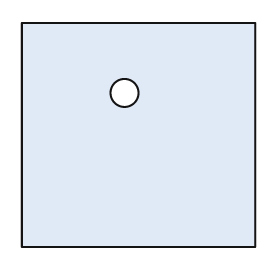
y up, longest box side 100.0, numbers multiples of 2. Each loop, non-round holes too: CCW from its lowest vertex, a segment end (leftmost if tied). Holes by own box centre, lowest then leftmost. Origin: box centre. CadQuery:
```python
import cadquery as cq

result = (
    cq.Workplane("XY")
    .moveTo(-50.0, -48.0)
    .lineTo(50.0, -48.0)
    .lineTo(50.0, 48.0)
    .lineTo(-50.0, 48.0)
    .close()
    .moveTo(-6.0, 18.0)
    .circle(6.0)
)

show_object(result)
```